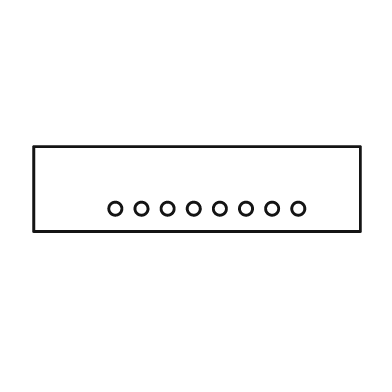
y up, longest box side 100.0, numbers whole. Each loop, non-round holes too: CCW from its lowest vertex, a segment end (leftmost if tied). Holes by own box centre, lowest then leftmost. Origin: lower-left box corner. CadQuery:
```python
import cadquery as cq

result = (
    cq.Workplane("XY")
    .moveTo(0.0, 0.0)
    .lineTo(100.0, 0.0)
    .lineTo(100.0, 26.0)
    .lineTo(0.0, 26.0)
    .close()
    .moveTo(25.0, 7.0)
    .circle(2.0)
    .moveTo(33.0, 7.0)
    .circle(2.0)
    .moveTo(41.0, 7.0)
    .circle(2.0)
    .moveTo(49.0, 7.0)
    .circle(2.0)
    .moveTo(57.0, 7.0)
    .circle(2.0)
    .moveTo(65.0, 7.0)
    .circle(2.0)
    .moveTo(73.0, 7.0)
    .circle(2.0)
    .moveTo(81.0, 7.0)
    .circle(2.0)
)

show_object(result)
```